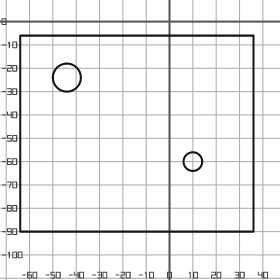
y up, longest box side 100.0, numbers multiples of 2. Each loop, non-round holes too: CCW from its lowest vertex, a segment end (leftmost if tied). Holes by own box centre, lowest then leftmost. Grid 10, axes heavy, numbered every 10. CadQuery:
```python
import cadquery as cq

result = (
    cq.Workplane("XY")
    .moveTo(-64.0, -90.0)
    .lineTo(36.0, -90.0)
    .lineTo(36.0, -6.0)
    .lineTo(-64.0, -6.0)
    .close()
    .moveTo(10.0, -60.0)
    .circle(4.0)
    .moveTo(-44.0, -24.0)
    .circle(6.0)
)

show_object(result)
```